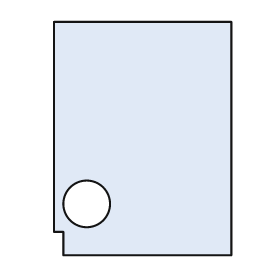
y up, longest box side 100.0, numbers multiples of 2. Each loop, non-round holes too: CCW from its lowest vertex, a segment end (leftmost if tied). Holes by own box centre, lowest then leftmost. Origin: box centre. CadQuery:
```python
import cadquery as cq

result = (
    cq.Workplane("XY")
    .moveTo(-34.0, -50.0)
    .lineTo(38.0, -50.0)
    .lineTo(38.0, 50.0)
    .lineTo(-38.0, 50.0)
    .lineTo(-38.0, -40.0)
    .lineTo(-34.0, -40.0)
    .close()
    .moveTo(-24.0, -28.0)
    .circle(10.0)
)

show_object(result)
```